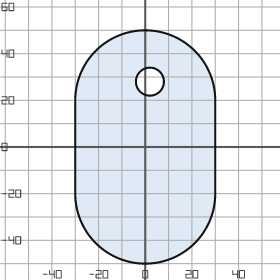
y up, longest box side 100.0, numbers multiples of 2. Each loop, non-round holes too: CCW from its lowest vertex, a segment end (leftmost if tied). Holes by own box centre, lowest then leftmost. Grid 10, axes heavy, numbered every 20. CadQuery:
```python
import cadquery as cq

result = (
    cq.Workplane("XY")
    .moveTo(-30.0, -20.0)
    .threePointArc((0.0, -50.0), (30.0, -20.0))
    .lineTo(30.0, 20.0)
    .threePointArc((0.0, 50.0), (-30.0, 20.0))
    .close()
    .moveTo(2.0, 28.0)
    .circle(6.0)
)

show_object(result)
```